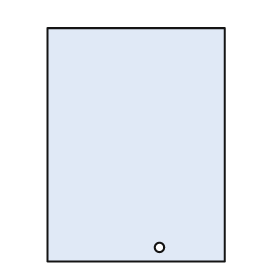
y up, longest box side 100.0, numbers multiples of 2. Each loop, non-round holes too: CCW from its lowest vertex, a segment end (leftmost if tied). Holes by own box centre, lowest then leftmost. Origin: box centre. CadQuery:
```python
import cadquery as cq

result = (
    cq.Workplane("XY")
    .moveTo(-38.0, -50.0)
    .lineTo(38.0, -50.0)
    .lineTo(38.0, 50.0)
    .lineTo(-38.0, 50.0)
    .close()
    .moveTo(10.0, -44.0)
    .circle(2.0)
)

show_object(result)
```